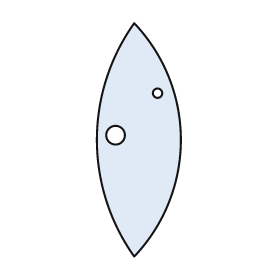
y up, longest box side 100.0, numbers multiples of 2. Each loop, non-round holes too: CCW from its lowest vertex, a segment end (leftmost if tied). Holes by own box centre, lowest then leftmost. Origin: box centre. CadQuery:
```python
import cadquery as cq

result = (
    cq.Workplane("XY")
    .moveTo(-2.0, -50.0)
    .threePointArc((18.0, 0.0), (-2.0, 50.0))
    .threePointArc((-18.0, 0.0), (-2.0, -50.0))
    .close()
    .moveTo(-10.0, 2.0)
    .circle(4.0)
    .moveTo(8.0, 20.0)
    .circle(2.0)
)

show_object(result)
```